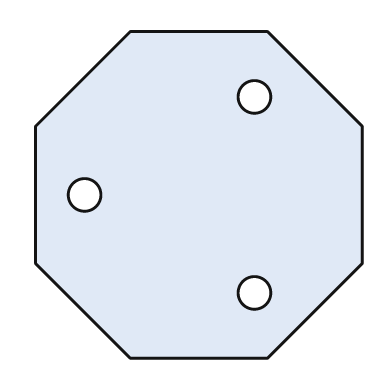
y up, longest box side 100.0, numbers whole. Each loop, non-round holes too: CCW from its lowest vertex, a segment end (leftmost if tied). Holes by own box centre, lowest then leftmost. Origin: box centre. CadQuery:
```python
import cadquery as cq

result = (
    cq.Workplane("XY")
    .moveTo(-21.0, -50.0)
    .lineTo(21.0, -50.0)
    .lineTo(50.0, -21.0)
    .lineTo(50.0, 21.0)
    .lineTo(21.0, 50.0)
    .lineTo(-21.0, 50.0)
    .lineTo(-50.0, 21.0)
    .lineTo(-50.0, -21.0)
    .close()
    .moveTo(17.0, -30.0)
    .circle(5.0)
    .moveTo(-35.0, 0.0)
    .circle(5.0)
    .moveTo(17.0, 30.0)
    .circle(5.0)
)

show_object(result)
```